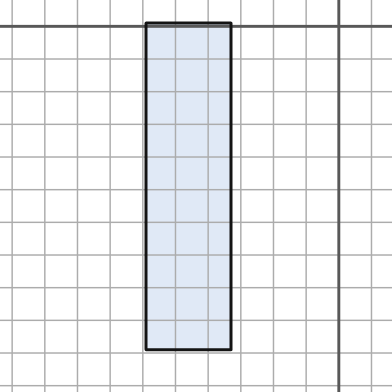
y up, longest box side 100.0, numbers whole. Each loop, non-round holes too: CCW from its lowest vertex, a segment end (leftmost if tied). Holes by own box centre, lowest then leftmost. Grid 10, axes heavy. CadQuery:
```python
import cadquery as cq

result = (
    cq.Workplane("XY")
    .moveTo(-59.0, -99.0)
    .lineTo(-33.0, -99.0)
    .lineTo(-33.0, 1.0)
    .lineTo(-59.0, 1.0)
    .close()
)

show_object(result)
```